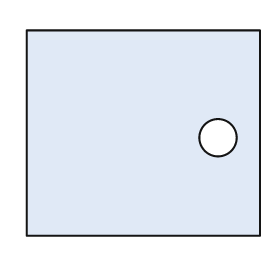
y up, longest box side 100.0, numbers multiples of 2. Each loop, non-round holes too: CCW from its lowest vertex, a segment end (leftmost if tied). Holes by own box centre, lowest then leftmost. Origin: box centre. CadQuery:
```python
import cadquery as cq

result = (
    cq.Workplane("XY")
    .moveTo(-50.0, -44.0)
    .lineTo(50.0, -44.0)
    .lineTo(50.0, 44.0)
    .lineTo(-50.0, 44.0)
    .close()
    .moveTo(32.0, -2.0)
    .circle(8.0)
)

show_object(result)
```